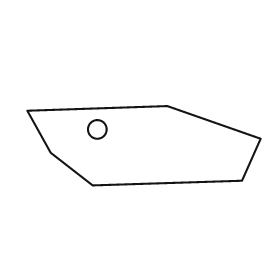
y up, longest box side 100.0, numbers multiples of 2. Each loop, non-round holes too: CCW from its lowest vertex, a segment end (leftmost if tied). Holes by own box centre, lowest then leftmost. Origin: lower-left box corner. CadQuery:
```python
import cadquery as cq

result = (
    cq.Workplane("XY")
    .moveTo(28.0, 0.0)
    .lineTo(92.0, 2.0)
    .lineTo(100.0, 20.0)
    .lineTo(60.0, 34.0)
    .lineTo(0.0, 32.0)
    .lineTo(10.0, 14.0)
    .close()
    .moveTo(30.0, 24.0)
    .circle(4.0)
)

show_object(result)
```